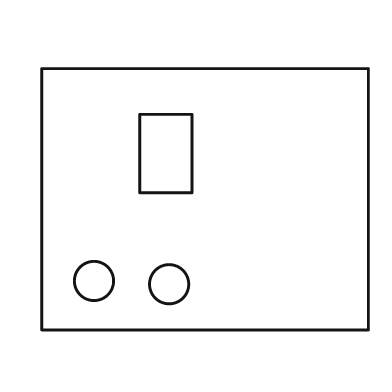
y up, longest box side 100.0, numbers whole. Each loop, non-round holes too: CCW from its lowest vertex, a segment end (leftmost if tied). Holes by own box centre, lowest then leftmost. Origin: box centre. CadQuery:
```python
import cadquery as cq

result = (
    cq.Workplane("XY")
    .moveTo(-50.0, -40.0)
    .lineTo(50.0, -40.0)
    .lineTo(50.0, 40.0)
    .lineTo(-50.0, 40.0)
    .close()
    .moveTo(-11.0, -26.0)
    .circle(6.0)
    .moveTo(-34.0, -25.0)
    .circle(6.0)
    .moveTo(-20.0, 2.0)
    .lineTo(-4.0, 2.0)
    .lineTo(-4.0, 26.0)
    .lineTo(-20.0, 26.0)
    .close()
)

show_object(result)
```